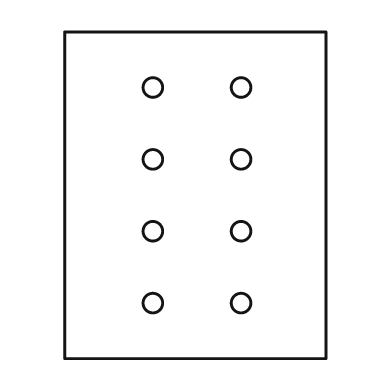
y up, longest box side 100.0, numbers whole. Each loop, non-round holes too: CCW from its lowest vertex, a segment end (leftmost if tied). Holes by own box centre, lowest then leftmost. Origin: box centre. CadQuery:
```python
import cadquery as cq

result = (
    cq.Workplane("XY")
    .moveTo(-40.0, -50.0)
    .lineTo(40.0, -50.0)
    .lineTo(40.0, 50.0)
    .lineTo(-40.0, 50.0)
    .close()
    .moveTo(-13.0, -33.0)
    .circle(3.0)
    .moveTo(14.0, -33.0)
    .circle(3.0)
    .moveTo(-13.0, -11.0)
    .circle(3.0)
    .moveTo(14.0, -11.0)
    .circle(3.0)
    .moveTo(-13.0, 11.0)
    .circle(3.0)
    .moveTo(14.0, 11.0)
    .circle(3.0)
    .moveTo(-13.0, 33.0)
    .circle(3.0)
    .moveTo(14.0, 33.0)
    .circle(3.0)
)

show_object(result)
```